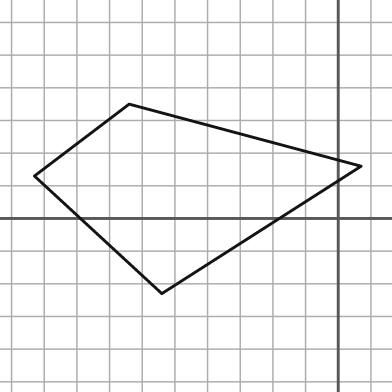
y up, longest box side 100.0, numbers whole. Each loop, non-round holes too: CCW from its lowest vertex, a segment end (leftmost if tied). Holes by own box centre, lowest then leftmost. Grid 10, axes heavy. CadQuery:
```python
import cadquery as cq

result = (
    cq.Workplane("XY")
    .moveTo(-54.0, -23.0)
    .lineTo(7.0, 16.0)
    .lineTo(-64.0, 35.0)
    .lineTo(-93.0, 13.0)
    .close()
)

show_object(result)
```